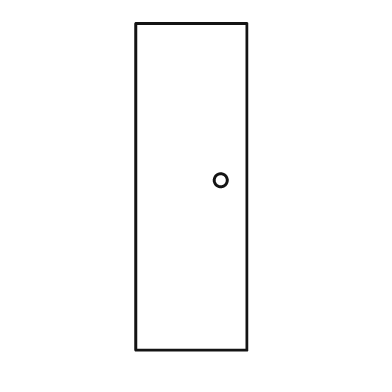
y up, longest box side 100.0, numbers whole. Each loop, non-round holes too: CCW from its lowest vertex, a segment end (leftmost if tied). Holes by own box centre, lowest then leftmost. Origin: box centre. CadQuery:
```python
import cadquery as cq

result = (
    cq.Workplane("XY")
    .moveTo(-17.0, -50.0)
    .lineTo(17.0, -50.0)
    .lineTo(17.0, 50.0)
    .lineTo(-17.0, 50.0)
    .close()
    .moveTo(9.0, 2.0)
    .circle(2.0)
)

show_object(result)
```